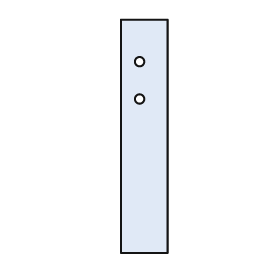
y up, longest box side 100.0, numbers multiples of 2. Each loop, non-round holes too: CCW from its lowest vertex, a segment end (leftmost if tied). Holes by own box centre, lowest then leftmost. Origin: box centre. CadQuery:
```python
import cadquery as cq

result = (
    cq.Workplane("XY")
    .moveTo(-10.0, -50.0)
    .lineTo(10.0, -50.0)
    .lineTo(10.0, 50.0)
    .lineTo(-10.0, 50.0)
    .close()
    .moveTo(-2.0, 16.0)
    .circle(2.0)
    .moveTo(-2.0, 32.0)
    .circle(2.0)
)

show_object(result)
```